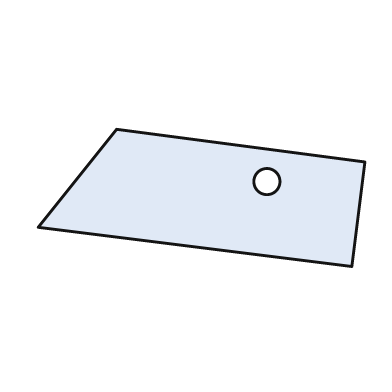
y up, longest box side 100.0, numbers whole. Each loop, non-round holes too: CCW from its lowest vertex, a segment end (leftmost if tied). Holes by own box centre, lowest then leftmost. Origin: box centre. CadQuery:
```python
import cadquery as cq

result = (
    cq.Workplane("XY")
    .moveTo(46.0, -21.0)
    .lineTo(50.0, 11.0)
    .lineTo(-26.0, 21.0)
    .lineTo(-50.0, -9.0)
    .close()
    .moveTo(20.0, 5.0)
    .circle(4.0)
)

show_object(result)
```